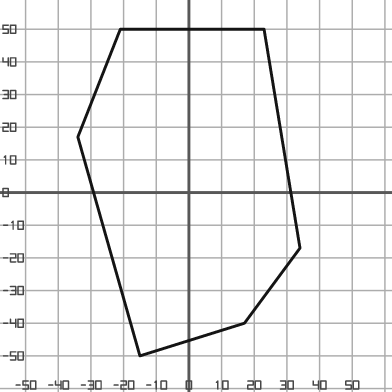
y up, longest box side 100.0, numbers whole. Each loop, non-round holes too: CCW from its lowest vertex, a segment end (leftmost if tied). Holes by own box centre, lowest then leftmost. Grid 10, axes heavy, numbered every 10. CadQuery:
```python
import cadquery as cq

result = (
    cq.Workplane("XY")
    .moveTo(-15.0, -50.0)
    .lineTo(17.0, -40.0)
    .lineTo(34.0, -17.0)
    .lineTo(23.0, 50.0)
    .lineTo(-21.0, 50.0)
    .lineTo(-34.0, 17.0)
    .close()
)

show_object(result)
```